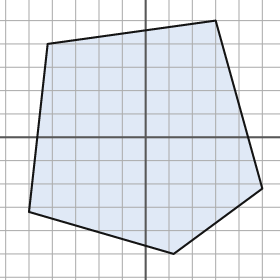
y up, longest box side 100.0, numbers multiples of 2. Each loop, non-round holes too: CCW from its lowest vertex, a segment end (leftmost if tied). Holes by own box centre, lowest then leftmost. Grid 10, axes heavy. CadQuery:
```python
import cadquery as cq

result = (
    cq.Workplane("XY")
    .moveTo(12.0, -50.0)
    .lineTo(50.0, -22.0)
    .lineTo(30.0, 50.0)
    .lineTo(-42.0, 40.0)
    .lineTo(-50.0, -32.0)
    .close()
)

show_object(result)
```